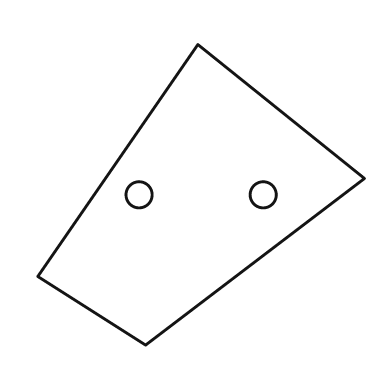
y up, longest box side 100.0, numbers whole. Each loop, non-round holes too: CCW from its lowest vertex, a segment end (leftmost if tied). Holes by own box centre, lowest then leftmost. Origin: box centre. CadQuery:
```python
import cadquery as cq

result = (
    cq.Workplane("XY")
    .moveTo(-17.0, -46.0)
    .lineTo(50.0, 5.0)
    .lineTo(-1.0, 46.0)
    .lineTo(-50.0, -25.0)
    .close()
    .moveTo(-19.0, 0.0)
    .circle(4.0)
    .moveTo(19.0, 0.0)
    .circle(4.0)
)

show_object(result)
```